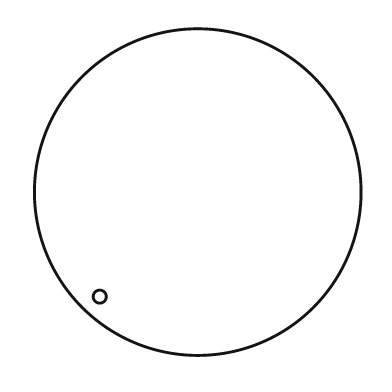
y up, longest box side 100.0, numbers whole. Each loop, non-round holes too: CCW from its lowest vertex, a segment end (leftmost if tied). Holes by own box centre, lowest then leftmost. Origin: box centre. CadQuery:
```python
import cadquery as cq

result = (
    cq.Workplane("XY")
    .moveTo(0.0, 0.0)
    .circle(50.0)
    .moveTo(-30.0, -32.0)
    .circle(2.0)
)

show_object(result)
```